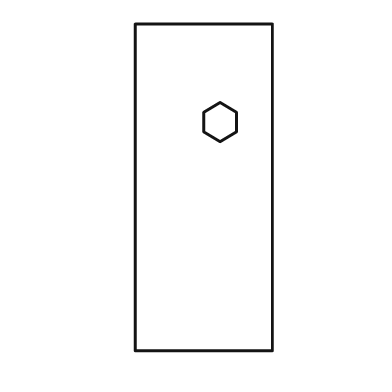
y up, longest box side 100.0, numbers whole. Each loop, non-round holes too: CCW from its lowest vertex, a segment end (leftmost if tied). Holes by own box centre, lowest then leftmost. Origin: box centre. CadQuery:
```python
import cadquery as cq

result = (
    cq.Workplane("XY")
    .moveTo(-21.0, -50.0)
    .lineTo(21.0, -50.0)
    .lineTo(21.0, 50.0)
    .lineTo(-21.0, 50.0)
    .close()
    .moveTo(5.0, 14.0)
    .lineTo(10.0, 17.0)
    .lineTo(10.0, 23.0)
    .lineTo(5.0, 26.0)
    .lineTo(0.0, 23.0)
    .lineTo(0.0, 17.0)
    .close()
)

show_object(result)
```